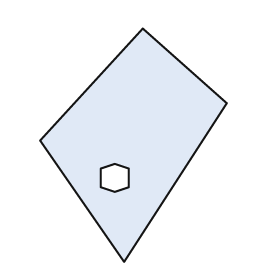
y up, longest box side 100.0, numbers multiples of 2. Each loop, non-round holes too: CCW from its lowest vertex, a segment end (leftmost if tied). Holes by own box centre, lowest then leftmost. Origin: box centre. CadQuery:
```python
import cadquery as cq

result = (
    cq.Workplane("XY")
    .moveTo(-4.0, -50.0)
    .lineTo(40.0, 18.0)
    .lineTo(4.0, 50.0)
    .lineTo(-40.0, 2.0)
    .close()
    .moveTo(-8.0, -20.0)
    .lineTo(-2.0, -18.0)
    .lineTo(-2.0, -10.0)
    .lineTo(-8.0, -8.0)
    .lineTo(-14.0, -10.0)
    .lineTo(-14.0, -18.0)
    .close()
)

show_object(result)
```